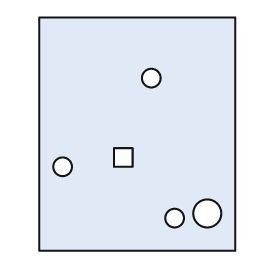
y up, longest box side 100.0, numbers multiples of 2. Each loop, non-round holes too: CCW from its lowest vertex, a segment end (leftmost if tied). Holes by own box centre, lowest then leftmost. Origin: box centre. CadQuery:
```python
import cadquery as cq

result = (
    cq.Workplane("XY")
    .moveTo(-42.0, -50.0)
    .lineTo(42.0, -50.0)
    .lineTo(42.0, 50.0)
    .lineTo(-42.0, 50.0)
    .close()
    .moveTo(16.0, -36.0)
    .circle(4.0)
    .moveTo(30.0, -34.0)
    .circle(6.0)
    .moveTo(-32.0, -14.0)
    .circle(4.0)
    .moveTo(-10.0, -14.0)
    .lineTo(-2.0, -14.0)
    .lineTo(-2.0, -6.0)
    .lineTo(-10.0, -6.0)
    .close()
    .moveTo(6.0, 24.0)
    .circle(4.0)
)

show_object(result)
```